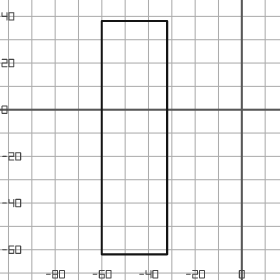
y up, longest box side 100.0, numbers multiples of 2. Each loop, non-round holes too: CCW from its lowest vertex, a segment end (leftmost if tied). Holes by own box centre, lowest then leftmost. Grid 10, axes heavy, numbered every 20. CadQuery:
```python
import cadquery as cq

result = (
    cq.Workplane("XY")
    .moveTo(-60.0, -62.0)
    .lineTo(-32.0, -62.0)
    .lineTo(-32.0, 38.0)
    .lineTo(-60.0, 38.0)
    .close()
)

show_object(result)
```